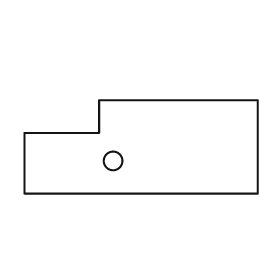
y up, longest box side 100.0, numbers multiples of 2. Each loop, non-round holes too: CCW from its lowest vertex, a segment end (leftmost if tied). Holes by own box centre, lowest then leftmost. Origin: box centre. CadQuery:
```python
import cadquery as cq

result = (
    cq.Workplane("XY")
    .moveTo(-50.0, -20.0)
    .lineTo(50.0, -20.0)
    .lineTo(50.0, 20.0)
    .lineTo(-18.0, 20.0)
    .lineTo(-18.0, 6.0)
    .lineTo(-50.0, 6.0)
    .close()
    .moveTo(-12.0, -6.0)
    .circle(4.0)
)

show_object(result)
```